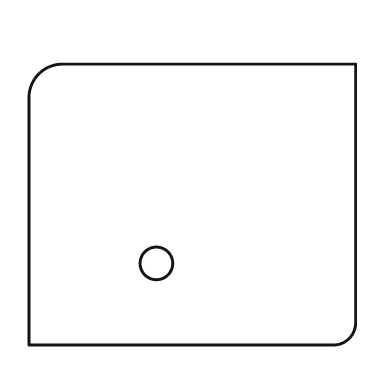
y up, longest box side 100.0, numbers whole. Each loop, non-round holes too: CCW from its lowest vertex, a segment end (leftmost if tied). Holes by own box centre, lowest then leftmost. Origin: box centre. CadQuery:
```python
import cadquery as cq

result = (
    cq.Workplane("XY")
    .moveTo(-50.0, -43.0)
    .lineTo(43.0, -43.0)
    .threePointArc((48.0, -41.0), (50.0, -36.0))
    .lineTo(50.0, 43.0)
    .lineTo(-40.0, 43.0)
    .threePointArc((-47.0, 40.0), (-50.0, 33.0))
    .close()
    .moveTo(-11.0, -18.0)
    .circle(5.0)
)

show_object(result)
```